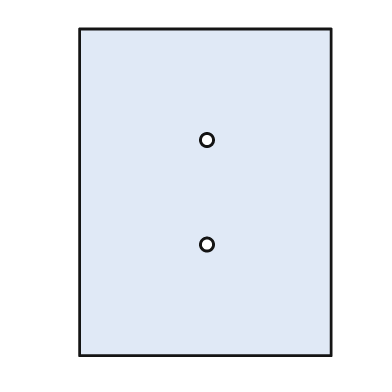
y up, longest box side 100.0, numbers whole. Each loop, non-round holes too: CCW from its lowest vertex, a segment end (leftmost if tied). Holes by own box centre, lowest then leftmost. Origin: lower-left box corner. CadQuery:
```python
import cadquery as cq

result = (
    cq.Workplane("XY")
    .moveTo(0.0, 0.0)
    .lineTo(77.0, 0.0)
    .lineTo(77.0, 100.0)
    .lineTo(0.0, 100.0)
    .close()
    .moveTo(39.0, 34.0)
    .circle(2.0)
    .moveTo(39.0, 66.0)
    .circle(2.0)
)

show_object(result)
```